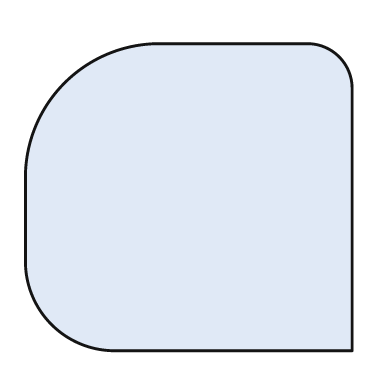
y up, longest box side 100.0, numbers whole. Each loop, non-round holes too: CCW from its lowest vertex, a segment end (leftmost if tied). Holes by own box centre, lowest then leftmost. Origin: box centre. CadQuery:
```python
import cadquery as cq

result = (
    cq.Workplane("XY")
    .moveTo(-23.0, -47.0)
    .lineTo(50.0, -47.0)
    .lineTo(50.0, 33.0)
    .threePointArc((46.0, 43.0), (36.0, 47.0))
    .lineTo(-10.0, 47.0)
    .threePointArc((-38.0, 35.0), (-50.0, 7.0))
    .lineTo(-50.0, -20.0)
    .threePointArc((-42.0, -39.0), (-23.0, -47.0))
    .close()
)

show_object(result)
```